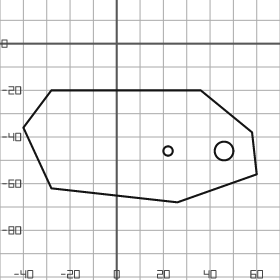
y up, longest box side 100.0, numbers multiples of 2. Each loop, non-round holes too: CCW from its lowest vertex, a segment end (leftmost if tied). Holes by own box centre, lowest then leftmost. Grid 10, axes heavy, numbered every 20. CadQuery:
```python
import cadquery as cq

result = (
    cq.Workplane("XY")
    .moveTo(26.0, -68.0)
    .lineTo(60.0, -56.0)
    .lineTo(58.0, -38.0)
    .lineTo(36.0, -20.0)
    .lineTo(-28.0, -20.0)
    .lineTo(-40.0, -36.0)
    .lineTo(-28.0, -62.0)
    .close()
    .moveTo(22.0, -46.0)
    .circle(2.0)
    .moveTo(46.0, -46.0)
    .circle(4.0)
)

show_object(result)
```